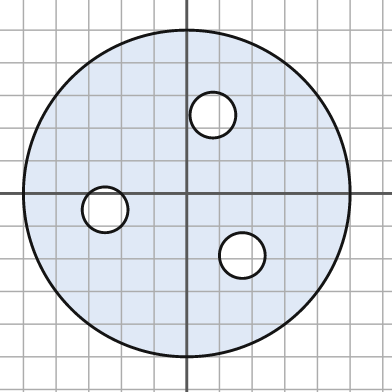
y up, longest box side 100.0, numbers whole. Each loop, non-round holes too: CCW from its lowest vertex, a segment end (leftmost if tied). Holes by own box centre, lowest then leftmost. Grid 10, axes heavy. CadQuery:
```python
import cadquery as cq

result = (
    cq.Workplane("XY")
    .moveTo(0.0, 0.0)
    .circle(50.0)
    .moveTo(17.0, -19.0)
    .circle(7.0)
    .moveTo(-25.0, -5.0)
    .circle(7.0)
    .moveTo(8.0, 24.0)
    .circle(7.0)
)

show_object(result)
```